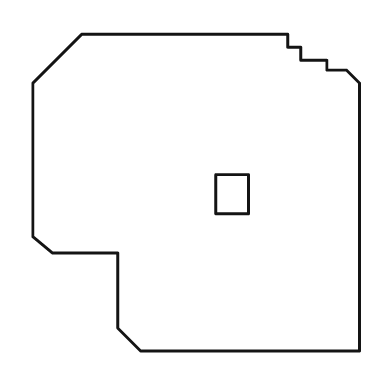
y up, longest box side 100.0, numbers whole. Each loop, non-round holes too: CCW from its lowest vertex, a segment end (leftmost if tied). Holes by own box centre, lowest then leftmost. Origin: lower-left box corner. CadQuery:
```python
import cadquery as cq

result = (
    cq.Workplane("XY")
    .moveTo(33.0, 0.0)
    .lineTo(100.0, 0.0)
    .lineTo(100.0, 82.0)
    .lineTo(96.0, 86.0)
    .lineTo(90.0, 86.0)
    .lineTo(90.0, 89.0)
    .lineTo(82.0, 89.0)
    .lineTo(82.0, 93.0)
    .lineTo(78.0, 93.0)
    .lineTo(78.0, 97.0)
    .lineTo(15.0, 97.0)
    .lineTo(0.0, 82.0)
    .lineTo(0.0, 35.0)
    .lineTo(6.0, 30.0)
    .lineTo(26.0, 30.0)
    .lineTo(26.0, 7.0)
    .close()
    .moveTo(56.0, 42.0)
    .lineTo(66.0, 42.0)
    .lineTo(66.0, 54.0)
    .lineTo(56.0, 54.0)
    .close()
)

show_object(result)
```